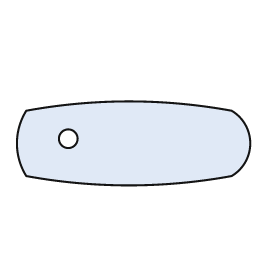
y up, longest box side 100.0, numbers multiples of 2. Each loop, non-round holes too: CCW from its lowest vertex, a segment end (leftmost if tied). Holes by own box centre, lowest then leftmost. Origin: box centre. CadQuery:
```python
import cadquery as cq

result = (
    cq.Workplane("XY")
    .moveTo(-46.0, -14.0)
    .threePointArc((-2.0, -18.0), (42.0, -14.0))
    .threePointArc((50.0, 0.0), (42.0, 14.0))
    .threePointArc((-2.0, 18.0), (-46.0, 14.0))
    .threePointArc((-50.0, 0.0), (-46.0, -14.0))
    .close()
    .moveTo(-28.0, 2.0)
    .circle(4.0)
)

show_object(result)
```